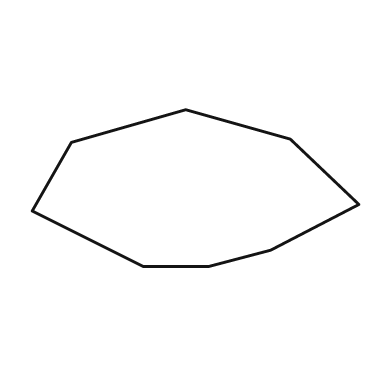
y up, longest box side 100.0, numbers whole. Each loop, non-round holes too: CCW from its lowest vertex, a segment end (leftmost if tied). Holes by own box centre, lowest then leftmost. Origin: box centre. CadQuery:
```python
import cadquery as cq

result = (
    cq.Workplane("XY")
    .moveTo(-16.0, -24.0)
    .lineTo(4.0, -24.0)
    .lineTo(23.0, -19.0)
    .lineTo(50.0, -5.0)
    .lineTo(29.0, 15.0)
    .lineTo(-3.0, 24.0)
    .lineTo(-38.0, 14.0)
    .lineTo(-50.0, -7.0)
    .close()
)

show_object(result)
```